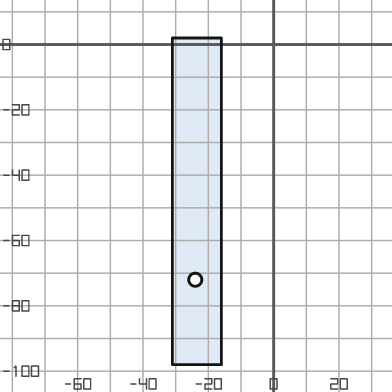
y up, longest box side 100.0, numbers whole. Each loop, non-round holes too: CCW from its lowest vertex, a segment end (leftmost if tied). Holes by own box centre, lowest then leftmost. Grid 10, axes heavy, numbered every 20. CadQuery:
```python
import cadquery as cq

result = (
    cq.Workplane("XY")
    .moveTo(-31.0, -98.0)
    .lineTo(-16.0, -98.0)
    .lineTo(-16.0, 2.0)
    .lineTo(-31.0, 2.0)
    .close()
    .moveTo(-24.0, -72.0)
    .circle(2.0)
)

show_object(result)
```